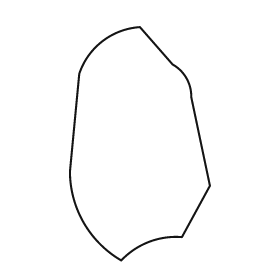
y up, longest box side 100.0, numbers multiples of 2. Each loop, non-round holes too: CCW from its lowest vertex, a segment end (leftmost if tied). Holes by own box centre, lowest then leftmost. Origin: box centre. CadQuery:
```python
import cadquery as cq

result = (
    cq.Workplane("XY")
    .moveTo(-8.0, -50.0)
    .threePointArc((4.0, -42.0), (18.0, -40.0))
    .lineTo(30.0, -18.0)
    .lineTo(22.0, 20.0)
    .threePointArc((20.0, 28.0), (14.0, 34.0))
    .lineTo(0.0, 50.0)
    .threePointArc((-16.0, 44.0), (-26.0, 30.0))
    .lineTo(-30.0, -12.0)
    .threePointArc((-24.0, -34.0), (-8.0, -50.0))
    .close()
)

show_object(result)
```